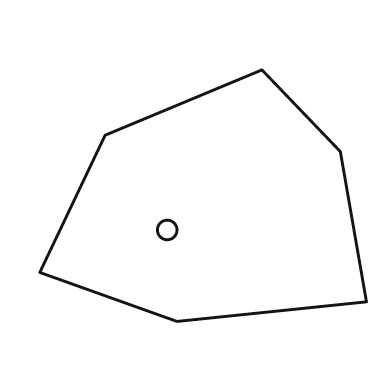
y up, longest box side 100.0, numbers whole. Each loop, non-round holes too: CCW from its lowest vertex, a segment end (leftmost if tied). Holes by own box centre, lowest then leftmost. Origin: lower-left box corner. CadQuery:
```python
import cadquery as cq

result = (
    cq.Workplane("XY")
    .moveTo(42.0, 0.0)
    .lineTo(100.0, 6.0)
    .lineTo(92.0, 52.0)
    .lineTo(68.0, 77.0)
    .lineTo(20.0, 57.0)
    .lineTo(0.0, 15.0)
    .close()
    .moveTo(39.0, 28.0)
    .circle(3.0)
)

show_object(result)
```